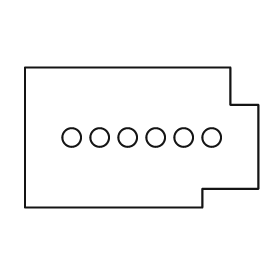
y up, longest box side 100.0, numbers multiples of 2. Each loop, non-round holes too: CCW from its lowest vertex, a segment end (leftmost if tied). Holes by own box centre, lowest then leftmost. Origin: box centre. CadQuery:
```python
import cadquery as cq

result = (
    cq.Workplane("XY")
    .moveTo(-50.0, -30.0)
    .lineTo(26.0, -30.0)
    .lineTo(26.0, -22.0)
    .lineTo(50.0, -22.0)
    .lineTo(50.0, 14.0)
    .lineTo(38.0, 14.0)
    .lineTo(38.0, 30.0)
    .lineTo(-50.0, 30.0)
    .close()
    .moveTo(-30.0, 0.0)
    .circle(4.0)
    .moveTo(-18.0, 0.0)
    .circle(4.0)
    .moveTo(-6.0, 0.0)
    .circle(4.0)
    .moveTo(6.0, 0.0)
    .circle(4.0)
    .moveTo(18.0, 0.0)
    .circle(4.0)
    .moveTo(30.0, 0.0)
    .circle(4.0)
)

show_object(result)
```